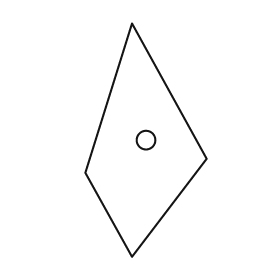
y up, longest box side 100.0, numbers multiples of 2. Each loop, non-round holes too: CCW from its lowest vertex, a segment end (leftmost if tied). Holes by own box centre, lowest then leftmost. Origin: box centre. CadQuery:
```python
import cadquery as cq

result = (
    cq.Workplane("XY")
    .moveTo(-6.0, -50.0)
    .lineTo(26.0, -8.0)
    .lineTo(-6.0, 50.0)
    .lineTo(-26.0, -14.0)
    .close()
    .moveTo(0.0, 0.0)
    .circle(4.0)
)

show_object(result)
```